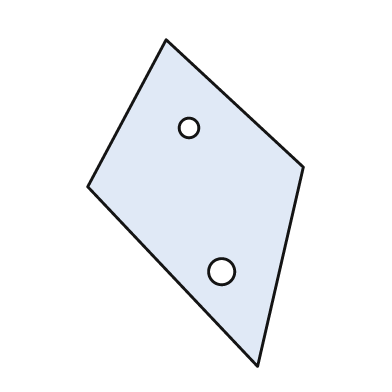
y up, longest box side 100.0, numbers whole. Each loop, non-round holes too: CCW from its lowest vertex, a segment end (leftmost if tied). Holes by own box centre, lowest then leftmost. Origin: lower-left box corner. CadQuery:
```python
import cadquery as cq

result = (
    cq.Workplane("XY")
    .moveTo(52.0, 0.0)
    .lineTo(66.0, 61.0)
    .lineTo(24.0, 100.0)
    .lineTo(0.0, 55.0)
    .close()
    .moveTo(41.0, 29.0)
    .circle(4.0)
    .moveTo(31.0, 73.0)
    .circle(3.0)
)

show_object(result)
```